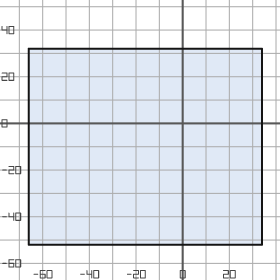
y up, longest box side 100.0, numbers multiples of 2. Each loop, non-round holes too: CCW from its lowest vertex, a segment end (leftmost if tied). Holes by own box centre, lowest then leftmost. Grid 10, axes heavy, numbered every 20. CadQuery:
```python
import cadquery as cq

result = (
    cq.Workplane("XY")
    .moveTo(-66.0, -52.0)
    .lineTo(34.0, -52.0)
    .lineTo(34.0, 32.0)
    .lineTo(-66.0, 32.0)
    .close()
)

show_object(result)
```